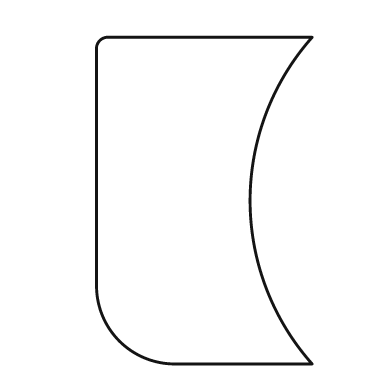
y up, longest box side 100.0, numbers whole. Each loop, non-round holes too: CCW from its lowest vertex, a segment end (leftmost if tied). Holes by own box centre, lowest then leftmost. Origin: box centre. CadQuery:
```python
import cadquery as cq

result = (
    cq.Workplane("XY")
    .moveTo(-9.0, -50.0)
    .lineTo(33.0, -50.0)
    .threePointArc((14.0, 0.0), (33.0, 50.0))
    .lineTo(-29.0, 50.0)
    .threePointArc((-32.0, 49.0), (-33.0, 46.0))
    .lineTo(-33.0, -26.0)
    .threePointArc((-26.0, -43.0), (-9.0, -50.0))
    .close()
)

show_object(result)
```